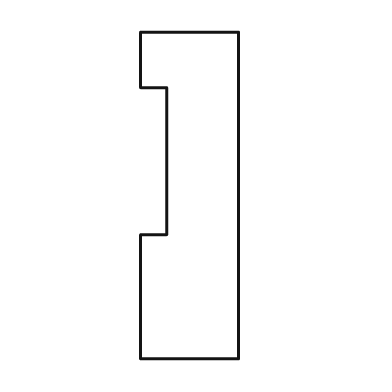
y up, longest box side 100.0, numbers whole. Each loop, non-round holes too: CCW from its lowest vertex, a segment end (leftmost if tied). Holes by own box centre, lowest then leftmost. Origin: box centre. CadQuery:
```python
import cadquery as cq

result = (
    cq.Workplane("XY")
    .moveTo(-15.0, -50.0)
    .lineTo(15.0, -50.0)
    .lineTo(15.0, 50.0)
    .lineTo(-15.0, 50.0)
    .lineTo(-15.0, 33.0)
    .lineTo(-7.0, 33.0)
    .lineTo(-7.0, -12.0)
    .lineTo(-15.0, -12.0)
    .close()
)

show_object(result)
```